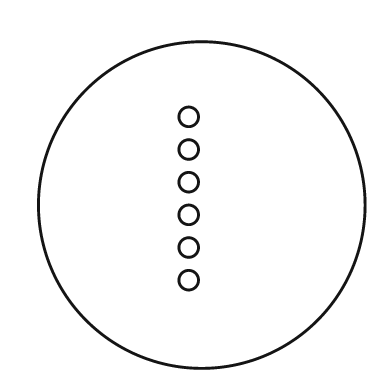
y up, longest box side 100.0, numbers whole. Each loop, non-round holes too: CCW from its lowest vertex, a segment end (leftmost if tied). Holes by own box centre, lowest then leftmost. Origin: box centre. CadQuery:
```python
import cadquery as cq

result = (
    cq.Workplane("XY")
    .moveTo(0.0, 0.0)
    .circle(50.0)
    .moveTo(-4.0, -23.0)
    .circle(3.0)
    .moveTo(-4.0, -13.0)
    .circle(3.0)
    .moveTo(-4.0, -3.0)
    .circle(3.0)
    .moveTo(-4.0, 7.0)
    .circle(3.0)
    .moveTo(-4.0, 17.0)
    .circle(3.0)
    .moveTo(-4.0, 27.0)
    .circle(3.0)
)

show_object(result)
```